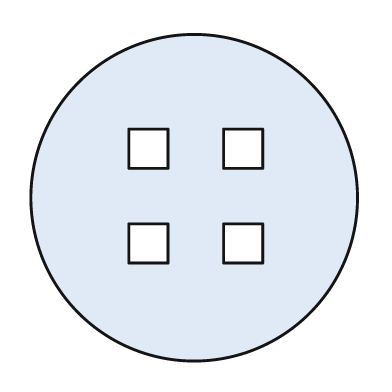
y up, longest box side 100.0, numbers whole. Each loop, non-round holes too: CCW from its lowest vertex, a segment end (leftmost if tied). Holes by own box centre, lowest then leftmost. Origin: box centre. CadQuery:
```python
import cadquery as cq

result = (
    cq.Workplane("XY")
    .moveTo(0.0, 0.0)
    .circle(50.0)
    .moveTo(-20.0, -20.0)
    .lineTo(-8.0, -20.0)
    .lineTo(-8.0, -8.0)
    .lineTo(-20.0, -8.0)
    .close()
    .moveTo(9.0, -20.0)
    .lineTo(21.0, -20.0)
    .lineTo(21.0, -8.0)
    .lineTo(9.0, -8.0)
    .close()
    .moveTo(-20.0, 9.0)
    .lineTo(-8.0, 9.0)
    .lineTo(-8.0, 21.0)
    .lineTo(-20.0, 21.0)
    .close()
    .moveTo(9.0, 9.0)
    .lineTo(21.0, 9.0)
    .lineTo(21.0, 21.0)
    .lineTo(9.0, 21.0)
    .close()
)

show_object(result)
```